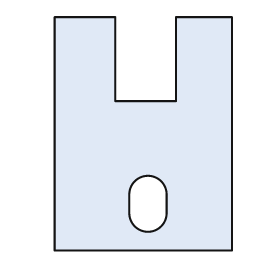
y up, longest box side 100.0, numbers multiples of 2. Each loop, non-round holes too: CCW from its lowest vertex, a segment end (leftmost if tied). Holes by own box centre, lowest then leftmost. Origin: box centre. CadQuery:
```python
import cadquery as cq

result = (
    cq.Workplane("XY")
    .moveTo(-38.0, -50.0)
    .lineTo(38.0, -50.0)
    .lineTo(38.0, 50.0)
    .lineTo(14.0, 50.0)
    .lineTo(14.0, 14.0)
    .lineTo(-12.0, 14.0)
    .lineTo(-12.0, 50.0)
    .lineTo(-38.0, 50.0)
    .close()
    .moveTo(-6.0, -34.0)
    .threePointArc((2.0, -42.0), (10.0, -34.0))
    .lineTo(10.0, -26.0)
    .threePointArc((2.0, -18.0), (-6.0, -26.0))
    .close()
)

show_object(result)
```